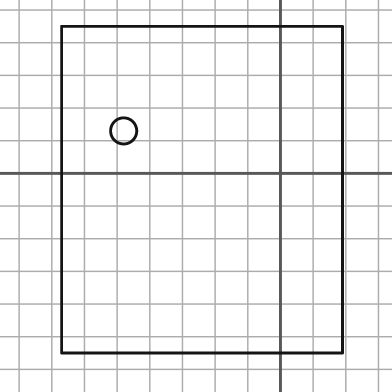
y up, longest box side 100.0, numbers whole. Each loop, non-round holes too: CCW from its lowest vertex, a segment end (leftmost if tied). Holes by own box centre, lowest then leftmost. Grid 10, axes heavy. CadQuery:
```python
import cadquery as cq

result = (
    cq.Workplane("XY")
    .moveTo(-67.0, -55.0)
    .lineTo(19.0, -55.0)
    .lineTo(19.0, 45.0)
    .lineTo(-67.0, 45.0)
    .close()
    .moveTo(-48.0, 13.0)
    .circle(4.0)
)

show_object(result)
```